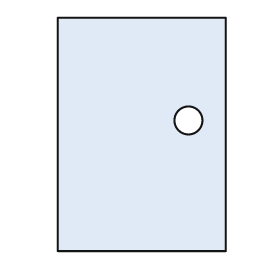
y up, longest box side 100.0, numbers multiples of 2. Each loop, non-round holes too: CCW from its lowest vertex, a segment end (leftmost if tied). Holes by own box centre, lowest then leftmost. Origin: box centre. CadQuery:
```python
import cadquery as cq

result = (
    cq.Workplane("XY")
    .moveTo(-36.0, -50.0)
    .lineTo(36.0, -50.0)
    .lineTo(36.0, 50.0)
    .lineTo(-36.0, 50.0)
    .close()
    .moveTo(20.0, 6.0)
    .circle(6.0)
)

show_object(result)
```